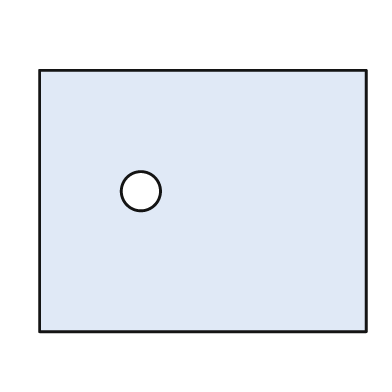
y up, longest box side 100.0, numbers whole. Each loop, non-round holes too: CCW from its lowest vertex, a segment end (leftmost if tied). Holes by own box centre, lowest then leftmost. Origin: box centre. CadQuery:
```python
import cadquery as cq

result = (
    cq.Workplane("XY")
    .moveTo(-50.0, -40.0)
    .lineTo(50.0, -40.0)
    .lineTo(50.0, 40.0)
    .lineTo(-50.0, 40.0)
    .close()
    .moveTo(-19.0, 3.0)
    .circle(6.0)
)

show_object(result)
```